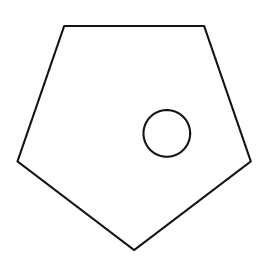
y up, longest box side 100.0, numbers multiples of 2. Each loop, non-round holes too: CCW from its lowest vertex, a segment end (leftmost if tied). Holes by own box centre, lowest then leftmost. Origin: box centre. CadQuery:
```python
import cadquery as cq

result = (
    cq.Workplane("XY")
    .moveTo(0.0, -48.0)
    .lineTo(50.0, -10.0)
    .lineTo(30.0, 48.0)
    .lineTo(-30.0, 48.0)
    .lineTo(-50.0, -10.0)
    .close()
    .moveTo(14.0, 2.0)
    .circle(10.0)
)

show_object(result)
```